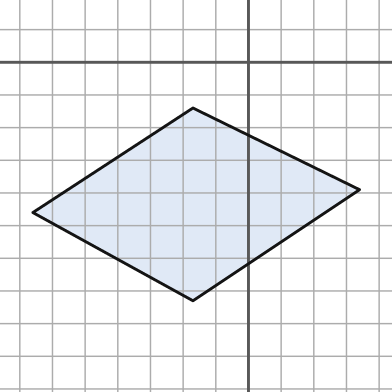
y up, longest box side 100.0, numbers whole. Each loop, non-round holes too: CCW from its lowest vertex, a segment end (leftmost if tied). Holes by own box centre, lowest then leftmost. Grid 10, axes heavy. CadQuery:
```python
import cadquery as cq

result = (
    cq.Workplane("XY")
    .moveTo(-17.0, -73.0)
    .lineTo(34.0, -39.0)
    .lineTo(-17.0, -14.0)
    .lineTo(-66.0, -46.0)
    .close()
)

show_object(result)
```